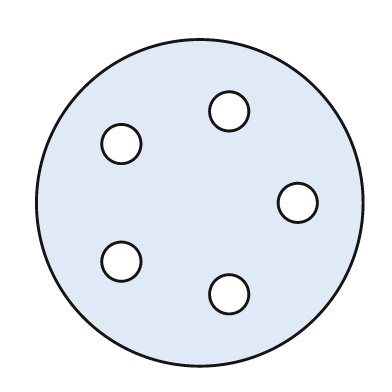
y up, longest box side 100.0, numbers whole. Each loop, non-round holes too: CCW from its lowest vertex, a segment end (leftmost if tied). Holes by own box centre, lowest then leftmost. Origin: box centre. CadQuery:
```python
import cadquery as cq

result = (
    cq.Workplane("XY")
    .moveTo(0.0, 0.0)
    .circle(50.0)
    .moveTo(9.0, -28.0)
    .circle(6.0)
    .moveTo(-24.0, -18.0)
    .circle(6.0)
    .moveTo(30.0, 0.0)
    .circle(6.0)
    .moveTo(-24.0, 18.0)
    .circle(6.0)
    .moveTo(9.0, 28.0)
    .circle(6.0)
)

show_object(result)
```